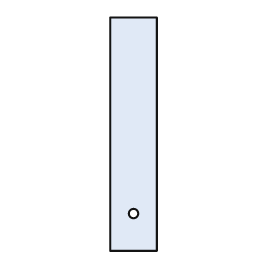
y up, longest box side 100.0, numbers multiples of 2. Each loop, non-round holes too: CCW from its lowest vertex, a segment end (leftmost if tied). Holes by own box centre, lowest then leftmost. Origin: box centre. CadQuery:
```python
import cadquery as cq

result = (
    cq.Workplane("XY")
    .moveTo(-10.0, -50.0)
    .lineTo(10.0, -50.0)
    .lineTo(10.0, 50.0)
    .lineTo(-10.0, 50.0)
    .close()
    .moveTo(0.0, -34.0)
    .circle(2.0)
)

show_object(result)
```